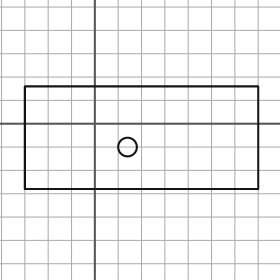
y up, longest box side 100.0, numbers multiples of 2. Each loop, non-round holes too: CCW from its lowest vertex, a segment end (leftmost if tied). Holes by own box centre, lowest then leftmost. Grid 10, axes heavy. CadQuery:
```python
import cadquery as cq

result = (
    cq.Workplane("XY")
    .moveTo(-30.0, -28.0)
    .lineTo(70.0, -28.0)
    .lineTo(70.0, 16.0)
    .lineTo(-30.0, 16.0)
    .close()
    .moveTo(14.0, -10.0)
    .circle(4.0)
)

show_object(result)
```